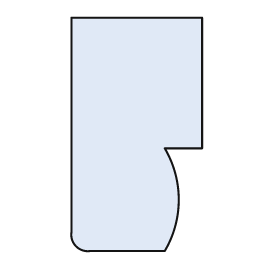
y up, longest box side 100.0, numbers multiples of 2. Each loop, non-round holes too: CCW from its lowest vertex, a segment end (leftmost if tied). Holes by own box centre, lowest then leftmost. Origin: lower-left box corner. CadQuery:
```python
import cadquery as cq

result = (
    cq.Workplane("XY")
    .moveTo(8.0, 0.0)
    .lineTo(40.0, 0.0)
    .threePointArc((46.0, 22.0), (40.0, 44.0))
    .lineTo(56.0, 44.0)
    .lineTo(56.0, 100.0)
    .lineTo(0.0, 100.0)
    .lineTo(0.0, 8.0)
    .threePointArc((2.0, 2.0), (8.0, 0.0))
    .close()
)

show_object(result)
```